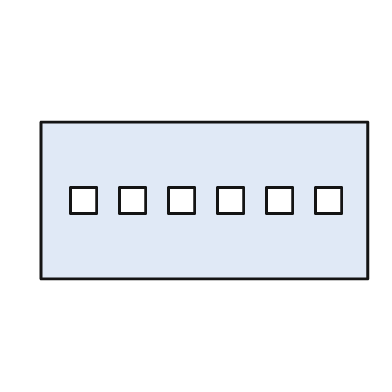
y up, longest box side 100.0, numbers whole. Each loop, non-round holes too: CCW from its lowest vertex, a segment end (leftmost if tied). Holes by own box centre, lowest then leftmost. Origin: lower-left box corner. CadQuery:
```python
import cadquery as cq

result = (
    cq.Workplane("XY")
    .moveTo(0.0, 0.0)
    .lineTo(100.0, 0.0)
    .lineTo(100.0, 48.0)
    .lineTo(0.0, 48.0)
    .close()
    .moveTo(9.0, 20.0)
    .lineTo(17.0, 20.0)
    .lineTo(17.0, 28.0)
    .lineTo(9.0, 28.0)
    .close()
    .moveTo(24.0, 20.0)
    .lineTo(32.0, 20.0)
    .lineTo(32.0, 28.0)
    .lineTo(24.0, 28.0)
    .close()
    .moveTo(39.0, 20.0)
    .lineTo(47.0, 20.0)
    .lineTo(47.0, 28.0)
    .lineTo(39.0, 28.0)
    .close()
    .moveTo(54.0, 20.0)
    .lineTo(62.0, 20.0)
    .lineTo(62.0, 28.0)
    .lineTo(54.0, 28.0)
    .close()
    .moveTo(69.0, 20.0)
    .lineTo(77.0, 20.0)
    .lineTo(77.0, 28.0)
    .lineTo(69.0, 28.0)
    .close()
    .moveTo(84.0, 20.0)
    .lineTo(92.0, 20.0)
    .lineTo(92.0, 28.0)
    .lineTo(84.0, 28.0)
    .close()
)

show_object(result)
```